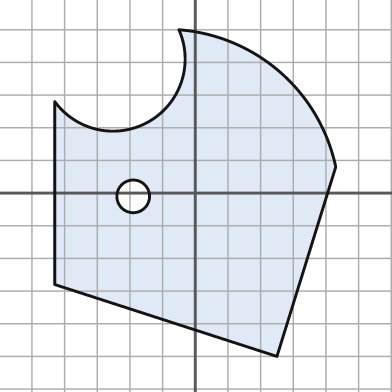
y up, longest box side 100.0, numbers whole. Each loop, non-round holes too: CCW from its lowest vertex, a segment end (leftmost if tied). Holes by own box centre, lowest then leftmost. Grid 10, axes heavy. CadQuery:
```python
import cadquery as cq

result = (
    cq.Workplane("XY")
    .moveTo(25.0, -50.0)
    .lineTo(43.0, 8.0)
    .threePointArc((26.0, 37.0), (-5.0, 50.0))
    .threePointArc((-14.0, 22.0), (-43.0, 28.0))
    .lineTo(-43.0, -28.0)
    .close()
    .moveTo(-19.0, -1.0)
    .circle(5.0)
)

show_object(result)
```